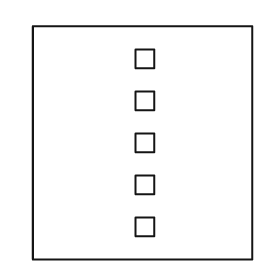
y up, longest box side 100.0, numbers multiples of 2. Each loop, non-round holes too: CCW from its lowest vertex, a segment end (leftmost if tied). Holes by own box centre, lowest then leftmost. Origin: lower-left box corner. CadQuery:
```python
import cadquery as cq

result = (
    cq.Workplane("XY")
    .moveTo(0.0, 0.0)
    .lineTo(94.0, 0.0)
    .lineTo(94.0, 100.0)
    .lineTo(0.0, 100.0)
    .close()
    .moveTo(44.0, 10.0)
    .lineTo(52.0, 10.0)
    .lineTo(52.0, 18.0)
    .lineTo(44.0, 18.0)
    .close()
    .moveTo(44.0, 28.0)
    .lineTo(52.0, 28.0)
    .lineTo(52.0, 36.0)
    .lineTo(44.0, 36.0)
    .close()
    .moveTo(44.0, 46.0)
    .lineTo(52.0, 46.0)
    .lineTo(52.0, 54.0)
    .lineTo(44.0, 54.0)
    .close()
    .moveTo(44.0, 64.0)
    .lineTo(52.0, 64.0)
    .lineTo(52.0, 72.0)
    .lineTo(44.0, 72.0)
    .close()
    .moveTo(44.0, 82.0)
    .lineTo(52.0, 82.0)
    .lineTo(52.0, 90.0)
    .lineTo(44.0, 90.0)
    .close()
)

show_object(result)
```